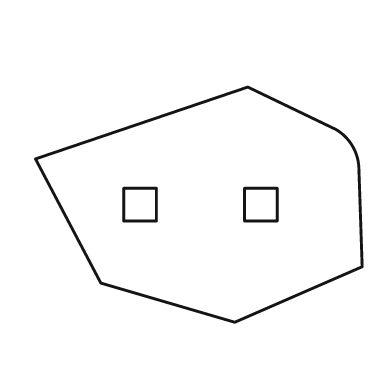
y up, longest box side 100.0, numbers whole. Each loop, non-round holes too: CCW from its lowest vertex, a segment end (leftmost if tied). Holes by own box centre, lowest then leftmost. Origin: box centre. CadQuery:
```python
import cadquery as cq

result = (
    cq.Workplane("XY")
    .moveTo(11.0, -36.0)
    .lineTo(50.0, -19.0)
    .lineTo(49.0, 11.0)
    .threePointArc((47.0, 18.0), (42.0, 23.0))
    .lineTo(15.0, 36.0)
    .lineTo(-50.0, 14.0)
    .lineTo(-30.0, -24.0)
    .close()
    .moveTo(-23.0, -5.0)
    .lineTo(-13.0, -5.0)
    .lineTo(-13.0, 5.0)
    .lineTo(-23.0, 5.0)
    .close()
    .moveTo(14.0, -5.0)
    .lineTo(24.0, -5.0)
    .lineTo(24.0, 5.0)
    .lineTo(14.0, 5.0)
    .close()
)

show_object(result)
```